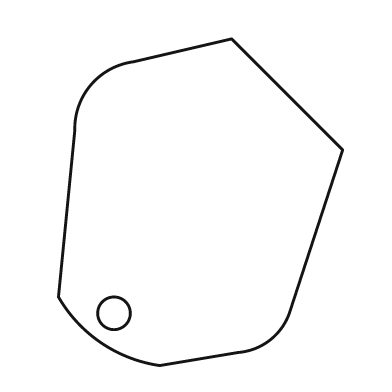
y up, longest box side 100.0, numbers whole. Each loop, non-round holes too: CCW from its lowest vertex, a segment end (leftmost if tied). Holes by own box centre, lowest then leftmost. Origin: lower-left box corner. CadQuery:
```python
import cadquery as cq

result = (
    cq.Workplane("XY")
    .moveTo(31.0, 0.0)
    .lineTo(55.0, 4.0)
    .threePointArc((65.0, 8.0), (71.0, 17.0))
    .lineTo(87.0, 66.0)
    .lineTo(53.0, 100.0)
    .lineTo(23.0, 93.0)
    .threePointArc((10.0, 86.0), (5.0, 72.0))
    .lineTo(0.0, 21.0)
    .threePointArc((13.0, 7.0), (31.0, 0.0))
    .close()
    .moveTo(17.0, 16.0)
    .circle(5.0)
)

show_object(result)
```